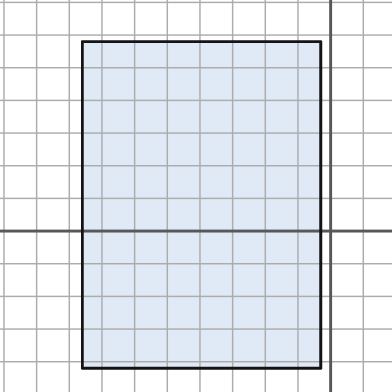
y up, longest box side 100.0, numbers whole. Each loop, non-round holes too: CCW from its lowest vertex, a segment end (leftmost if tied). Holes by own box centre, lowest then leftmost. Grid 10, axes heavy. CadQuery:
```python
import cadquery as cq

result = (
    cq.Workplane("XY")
    .moveTo(-76.0, -42.0)
    .lineTo(-3.0, -42.0)
    .lineTo(-3.0, 58.0)
    .lineTo(-76.0, 58.0)
    .close()
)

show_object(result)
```